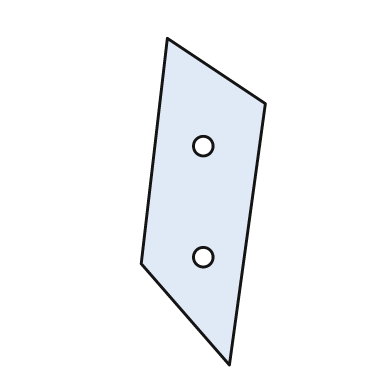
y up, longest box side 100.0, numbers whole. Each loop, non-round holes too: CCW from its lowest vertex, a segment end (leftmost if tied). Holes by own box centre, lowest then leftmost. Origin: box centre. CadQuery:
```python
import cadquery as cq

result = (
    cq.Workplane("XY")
    .moveTo(8.0, -50.0)
    .lineTo(19.0, 30.0)
    .lineTo(-11.0, 50.0)
    .lineTo(-19.0, -19.0)
    .close()
    .moveTo(0.0, -17.0)
    .circle(3.0)
    .moveTo(0.0, 17.0)
    .circle(3.0)
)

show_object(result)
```